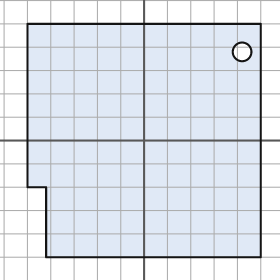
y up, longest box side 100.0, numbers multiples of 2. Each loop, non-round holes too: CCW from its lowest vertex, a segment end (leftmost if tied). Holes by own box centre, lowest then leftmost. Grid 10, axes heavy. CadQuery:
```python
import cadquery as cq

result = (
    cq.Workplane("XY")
    .moveTo(-42.0, -50.0)
    .lineTo(50.0, -50.0)
    .lineTo(50.0, 50.0)
    .lineTo(-50.0, 50.0)
    .lineTo(-50.0, -20.0)
    .lineTo(-42.0, -20.0)
    .close()
    .moveTo(42.0, 38.0)
    .circle(4.0)
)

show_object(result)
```